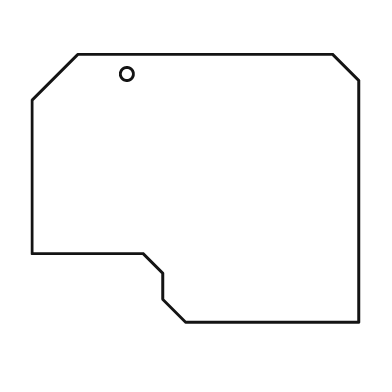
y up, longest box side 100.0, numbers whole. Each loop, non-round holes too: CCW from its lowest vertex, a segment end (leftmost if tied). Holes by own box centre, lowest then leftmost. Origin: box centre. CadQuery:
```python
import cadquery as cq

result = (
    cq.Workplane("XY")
    .moveTo(-3.0, -41.0)
    .lineTo(50.0, -41.0)
    .lineTo(50.0, 33.0)
    .lineTo(42.0, 41.0)
    .lineTo(-36.0, 41.0)
    .lineTo(-50.0, 27.0)
    .lineTo(-50.0, -20.0)
    .lineTo(-16.0, -20.0)
    .lineTo(-10.0, -26.0)
    .lineTo(-10.0, -34.0)
    .close()
    .moveTo(-21.0, 35.0)
    .circle(2.0)
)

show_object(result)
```